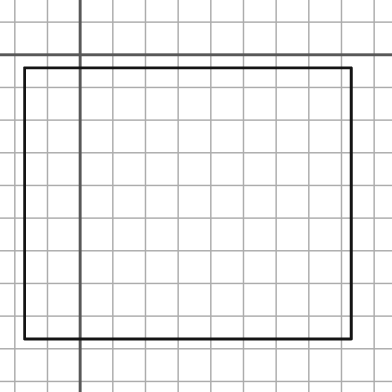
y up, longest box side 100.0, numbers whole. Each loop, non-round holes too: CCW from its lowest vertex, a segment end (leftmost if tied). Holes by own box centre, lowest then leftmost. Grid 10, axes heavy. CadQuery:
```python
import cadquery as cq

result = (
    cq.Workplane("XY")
    .moveTo(-17.0, -87.0)
    .lineTo(83.0, -87.0)
    .lineTo(83.0, -4.0)
    .lineTo(-17.0, -4.0)
    .close()
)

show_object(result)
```